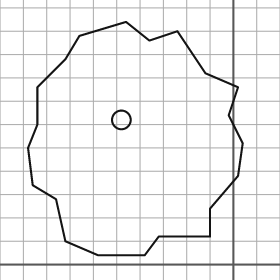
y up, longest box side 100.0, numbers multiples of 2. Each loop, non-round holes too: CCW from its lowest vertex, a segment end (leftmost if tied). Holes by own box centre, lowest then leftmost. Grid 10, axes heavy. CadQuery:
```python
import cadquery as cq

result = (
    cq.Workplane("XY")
    .moveTo(-58.0, 4.0)
    .lineTo(-38.0, 4.0)
    .lineTo(-32.0, 12.0)
    .lineTo(-10.0, 12.0)
    .lineTo(-10.0, 24.0)
    .lineTo(2.0, 38.0)
    .lineTo(4.0, 52.0)
    .lineTo(-2.0, 64.0)
    .lineTo(2.0, 76.0)
    .lineTo(-12.0, 82.0)
    .lineTo(-24.0, 100.0)
    .lineTo(-36.0, 96.0)
    .lineTo(-46.0, 104.0)
    .lineTo(-66.0, 98.0)
    .lineTo(-72.0, 88.0)
    .lineTo(-84.0, 76.0)
    .lineTo(-84.0, 60.0)
    .lineTo(-88.0, 50.0)
    .lineTo(-86.0, 34.0)
    .lineTo(-76.0, 28.0)
    .lineTo(-72.0, 10.0)
    .close()
    .moveTo(-48.0, 62.0)
    .circle(4.0)
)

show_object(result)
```